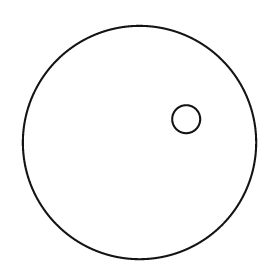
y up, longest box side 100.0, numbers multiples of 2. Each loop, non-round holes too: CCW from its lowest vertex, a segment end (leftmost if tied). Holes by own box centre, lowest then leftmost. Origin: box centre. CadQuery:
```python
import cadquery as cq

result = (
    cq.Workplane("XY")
    .moveTo(0.0, 0.0)
    .circle(50.0)
    .moveTo(20.0, 10.0)
    .circle(6.0)
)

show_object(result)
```